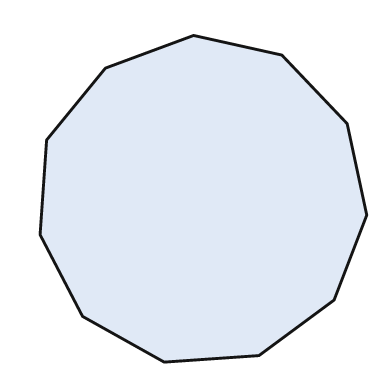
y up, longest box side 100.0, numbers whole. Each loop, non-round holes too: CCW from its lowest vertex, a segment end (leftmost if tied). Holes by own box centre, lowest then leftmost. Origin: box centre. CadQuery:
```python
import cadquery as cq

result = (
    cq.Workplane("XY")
    .moveTo(-12.0, -50.0)
    .lineTo(17.0, -48.0)
    .lineTo(40.0, -31.0)
    .lineTo(50.0, -5.0)
    .lineTo(44.0, 23.0)
    .lineTo(24.0, 44.0)
    .lineTo(-3.0, 50.0)
    .lineTo(-30.0, 40.0)
    .lineTo(-48.0, 18.0)
    .lineTo(-50.0, -11.0)
    .lineTo(-37.0, -36.0)
    .close()
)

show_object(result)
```